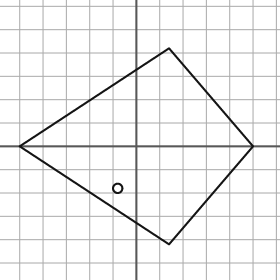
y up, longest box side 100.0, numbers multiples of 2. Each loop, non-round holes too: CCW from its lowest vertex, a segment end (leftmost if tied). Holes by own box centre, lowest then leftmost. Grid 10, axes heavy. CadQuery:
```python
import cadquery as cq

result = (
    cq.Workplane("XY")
    .moveTo(14.0, -42.0)
    .lineTo(50.0, 0.0)
    .lineTo(14.0, 42.0)
    .lineTo(-50.0, 0.0)
    .close()
    .moveTo(-8.0, -18.0)
    .circle(2.0)
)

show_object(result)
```